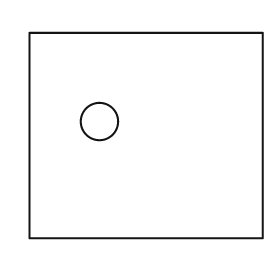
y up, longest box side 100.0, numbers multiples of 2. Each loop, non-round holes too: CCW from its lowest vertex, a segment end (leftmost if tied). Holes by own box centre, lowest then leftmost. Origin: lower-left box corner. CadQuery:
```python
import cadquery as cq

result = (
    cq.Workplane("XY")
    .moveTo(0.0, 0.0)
    .lineTo(100.0, 0.0)
    .lineTo(100.0, 88.0)
    .lineTo(0.0, 88.0)
    .close()
    .moveTo(30.0, 50.0)
    .circle(8.0)
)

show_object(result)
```